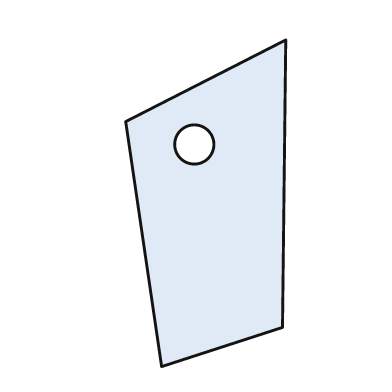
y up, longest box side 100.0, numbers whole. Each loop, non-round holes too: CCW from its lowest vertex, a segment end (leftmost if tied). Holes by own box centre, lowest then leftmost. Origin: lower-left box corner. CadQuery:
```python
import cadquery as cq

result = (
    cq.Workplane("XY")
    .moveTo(11.0, 0.0)
    .lineTo(48.0, 12.0)
    .lineTo(49.0, 100.0)
    .lineTo(0.0, 75.0)
    .close()
    .moveTo(21.0, 68.0)
    .circle(6.0)
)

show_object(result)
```